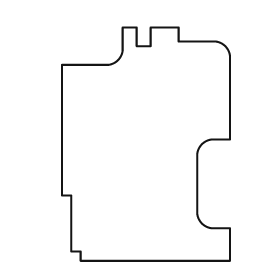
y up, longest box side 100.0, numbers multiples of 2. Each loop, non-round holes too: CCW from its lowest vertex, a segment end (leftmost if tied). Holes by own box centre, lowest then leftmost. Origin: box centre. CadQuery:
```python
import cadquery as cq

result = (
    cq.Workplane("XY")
    .moveTo(-28.0, -50.0)
    .lineTo(36.0, -50.0)
    .lineTo(36.0, -36.0)
    .lineTo(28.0, -36.0)
    .threePointArc((24.0, -34.0), (22.0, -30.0))
    .lineTo(22.0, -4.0)
    .threePointArc((24.0, 0.0), (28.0, 2.0))
    .lineTo(36.0, 2.0)
    .lineTo(36.0, 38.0)
    .threePointArc((34.0, 42.0), (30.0, 44.0))
    .lineTo(14.0, 44.0)
    .lineTo(14.0, 50.0)
    .lineTo(2.0, 50.0)
    .lineTo(2.0, 42.0)
    .lineTo(-4.0, 42.0)
    .lineTo(-4.0, 50.0)
    .lineTo(-10.0, 50.0)
    .lineTo(-10.0, 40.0)
    .threePointArc((-12.0, 36.0), (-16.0, 34.0))
    .lineTo(-36.0, 34.0)
    .lineTo(-36.0, -22.0)
    .lineTo(-32.0, -22.0)
    .lineTo(-32.0, -46.0)
    .lineTo(-28.0, -46.0)
    .close()
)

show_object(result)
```